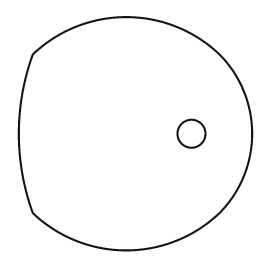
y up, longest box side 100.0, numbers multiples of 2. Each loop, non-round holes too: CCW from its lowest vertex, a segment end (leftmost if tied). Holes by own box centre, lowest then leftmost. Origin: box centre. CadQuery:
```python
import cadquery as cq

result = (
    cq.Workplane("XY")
    .moveTo(-44.0, -34.0)
    .threePointArc((-4.0, -50.0), (36.0, -34.0))
    .threePointArc((50.0, 0.0), (36.0, 34.0))
    .threePointArc((-4.0, 50.0), (-44.0, 34.0))
    .threePointArc((-50.0, 0.0), (-44.0, -34.0))
    .close()
    .moveTo(24.0, 0.0)
    .circle(6.0)
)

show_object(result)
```